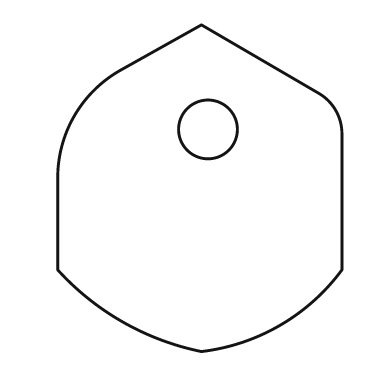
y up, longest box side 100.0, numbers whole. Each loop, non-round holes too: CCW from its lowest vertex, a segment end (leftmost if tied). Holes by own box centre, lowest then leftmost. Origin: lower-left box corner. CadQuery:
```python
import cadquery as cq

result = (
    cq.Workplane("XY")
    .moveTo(44.0, 0.0)
    .threePointArc((68.0, 8.0), (87.0, 25.0))
    .lineTo(87.0, 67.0)
    .threePointArc((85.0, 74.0), (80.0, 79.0))
    .lineTo(44.0, 100.0)
    .lineTo(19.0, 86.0)
    .threePointArc((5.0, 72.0), (0.0, 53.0))
    .lineTo(0.0, 25.0)
    .threePointArc((20.0, 9.0), (44.0, 0.0))
    .close()
    .moveTo(46.0, 68.0)
    .circle(9.0)
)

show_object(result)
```